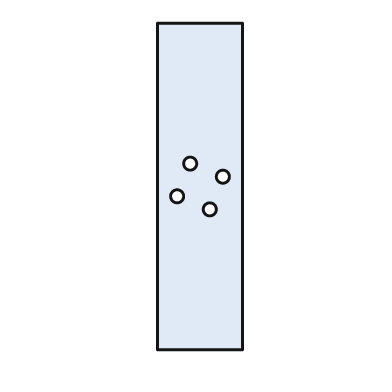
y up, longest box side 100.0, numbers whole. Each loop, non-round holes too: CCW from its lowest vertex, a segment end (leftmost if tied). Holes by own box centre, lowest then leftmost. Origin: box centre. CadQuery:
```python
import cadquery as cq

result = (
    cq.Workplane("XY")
    .moveTo(-13.0, -50.0)
    .lineTo(13.0, -50.0)
    .lineTo(13.0, 50.0)
    .lineTo(-13.0, 50.0)
    .close()
    .moveTo(3.0, -7.0)
    .circle(2.0)
    .moveTo(-7.0, -3.0)
    .circle(2.0)
    .moveTo(7.0, 3.0)
    .circle(2.0)
    .moveTo(-3.0, 7.0)
    .circle(2.0)
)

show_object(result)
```